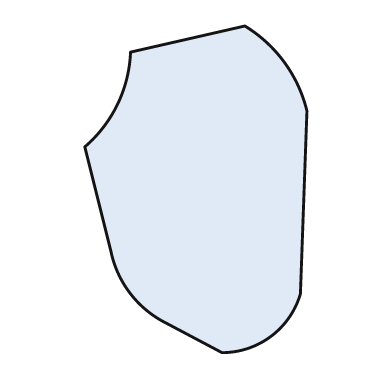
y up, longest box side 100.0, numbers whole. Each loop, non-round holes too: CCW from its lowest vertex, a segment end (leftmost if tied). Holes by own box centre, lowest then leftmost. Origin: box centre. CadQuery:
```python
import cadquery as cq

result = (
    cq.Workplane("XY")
    .moveTo(8.0, -50.0)
    .threePointArc((23.0, -45.0), (32.0, -32.0))
    .lineTo(34.0, 24.0)
    .threePointArc((27.0, 39.0), (15.0, 50.0))
    .lineTo(-20.0, 42.0)
    .threePointArc((-24.0, 26.0), (-34.0, 13.0))
    .lineTo(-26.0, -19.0)
    .threePointArc((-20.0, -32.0), (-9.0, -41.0))
    .close()
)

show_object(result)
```